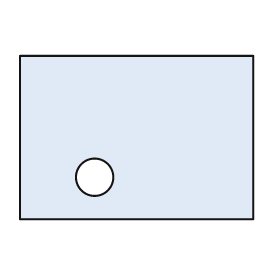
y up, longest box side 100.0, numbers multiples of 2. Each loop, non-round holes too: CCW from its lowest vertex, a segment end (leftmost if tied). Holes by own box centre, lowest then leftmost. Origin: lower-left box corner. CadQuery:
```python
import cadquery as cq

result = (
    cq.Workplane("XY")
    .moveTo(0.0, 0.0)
    .lineTo(100.0, 0.0)
    .lineTo(100.0, 70.0)
    .lineTo(0.0, 70.0)
    .close()
    .moveTo(32.0, 18.0)
    .circle(8.0)
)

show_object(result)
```